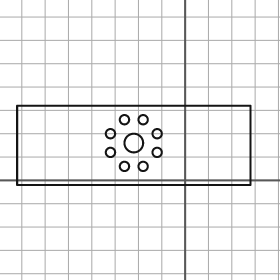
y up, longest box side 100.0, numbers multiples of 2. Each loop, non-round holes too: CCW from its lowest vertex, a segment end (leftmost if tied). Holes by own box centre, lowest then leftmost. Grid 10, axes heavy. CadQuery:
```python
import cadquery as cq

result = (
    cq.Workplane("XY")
    .moveTo(-72.0, -2.0)
    .lineTo(28.0, -2.0)
    .lineTo(28.0, 32.0)
    .lineTo(-72.0, 32.0)
    .close()
    .moveTo(-26.0, 6.0)
    .circle(2.0)
    .moveTo(-18.0, 6.0)
    .circle(2.0)
    .moveTo(-32.0, 12.0)
    .circle(2.0)
    .moveTo(-12.0, 12.0)
    .circle(2.0)
    .moveTo(-22.0, 16.0)
    .circle(4.0)
    .moveTo(-32.0, 20.0)
    .circle(2.0)
    .moveTo(-12.0, 20.0)
    .circle(2.0)
    .moveTo(-26.0, 26.0)
    .circle(2.0)
    .moveTo(-18.0, 26.0)
    .circle(2.0)
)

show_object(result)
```